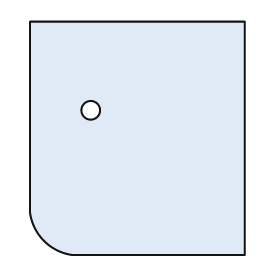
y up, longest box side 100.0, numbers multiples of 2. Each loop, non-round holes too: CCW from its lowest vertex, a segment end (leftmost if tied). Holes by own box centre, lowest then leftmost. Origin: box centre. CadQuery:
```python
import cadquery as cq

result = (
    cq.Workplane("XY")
    .moveTo(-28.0, -50.0)
    .lineTo(46.0, -50.0)
    .lineTo(46.0, 50.0)
    .lineTo(-46.0, 50.0)
    .lineTo(-46.0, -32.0)
    .threePointArc((-40.0, -44.0), (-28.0, -50.0))
    .close()
    .moveTo(-20.0, 12.0)
    .circle(4.0)
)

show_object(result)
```